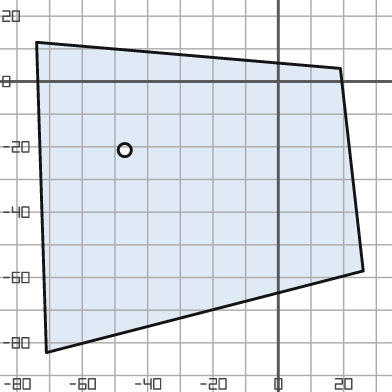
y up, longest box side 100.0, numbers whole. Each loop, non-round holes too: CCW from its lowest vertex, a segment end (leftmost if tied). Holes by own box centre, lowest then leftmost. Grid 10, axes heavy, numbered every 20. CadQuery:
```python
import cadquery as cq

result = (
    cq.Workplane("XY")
    .moveTo(-71.0, -83.0)
    .lineTo(26.0, -58.0)
    .lineTo(19.0, 4.0)
    .lineTo(-74.0, 12.0)
    .close()
    .moveTo(-47.0, -21.0)
    .circle(2.0)
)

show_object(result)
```